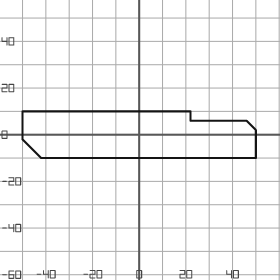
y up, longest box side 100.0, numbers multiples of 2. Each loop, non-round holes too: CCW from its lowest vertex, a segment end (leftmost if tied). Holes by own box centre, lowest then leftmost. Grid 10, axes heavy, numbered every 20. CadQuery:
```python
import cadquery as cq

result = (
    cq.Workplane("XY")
    .moveTo(-42.0, -10.0)
    .lineTo(50.0, -10.0)
    .lineTo(50.0, 2.0)
    .lineTo(46.0, 6.0)
    .lineTo(22.0, 6.0)
    .lineTo(22.0, 10.0)
    .lineTo(-50.0, 10.0)
    .lineTo(-50.0, -2.0)
    .close()
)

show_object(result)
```